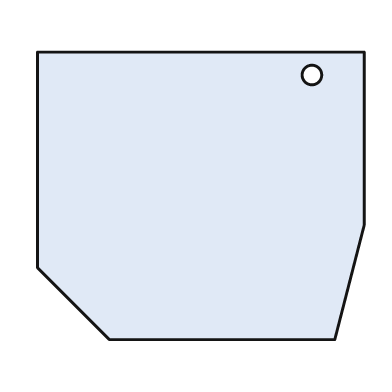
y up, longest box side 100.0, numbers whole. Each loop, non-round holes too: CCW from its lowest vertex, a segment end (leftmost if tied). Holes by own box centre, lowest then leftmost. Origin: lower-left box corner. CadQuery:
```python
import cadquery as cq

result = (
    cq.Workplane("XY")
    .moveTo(22.0, 0.0)
    .lineTo(91.0, 0.0)
    .lineTo(100.0, 35.0)
    .lineTo(100.0, 88.0)
    .lineTo(0.0, 88.0)
    .lineTo(0.0, 22.0)
    .close()
    .moveTo(84.0, 81.0)
    .circle(3.0)
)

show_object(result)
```